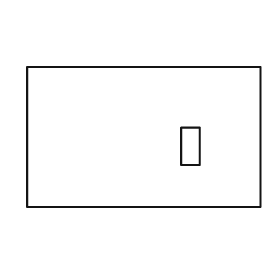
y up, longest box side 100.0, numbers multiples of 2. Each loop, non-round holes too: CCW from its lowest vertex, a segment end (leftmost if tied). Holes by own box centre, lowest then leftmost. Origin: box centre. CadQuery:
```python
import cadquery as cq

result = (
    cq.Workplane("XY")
    .moveTo(-50.0, -30.0)
    .lineTo(50.0, -30.0)
    .lineTo(50.0, 30.0)
    .lineTo(-50.0, 30.0)
    .close()
    .moveTo(16.0, -12.0)
    .lineTo(24.0, -12.0)
    .lineTo(24.0, 4.0)
    .lineTo(16.0, 4.0)
    .close()
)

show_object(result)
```